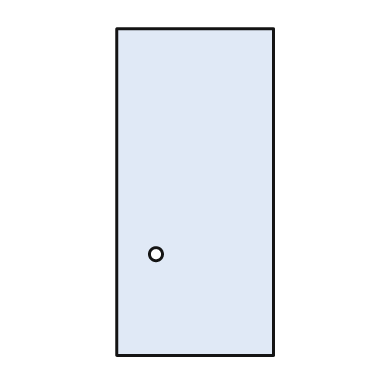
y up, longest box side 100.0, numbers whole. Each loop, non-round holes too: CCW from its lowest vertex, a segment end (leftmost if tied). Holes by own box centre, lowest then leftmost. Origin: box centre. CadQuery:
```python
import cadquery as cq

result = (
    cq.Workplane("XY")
    .moveTo(-24.0, -50.0)
    .lineTo(24.0, -50.0)
    .lineTo(24.0, 50.0)
    .lineTo(-24.0, 50.0)
    .close()
    .moveTo(-12.0, -19.0)
    .circle(2.0)
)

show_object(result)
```